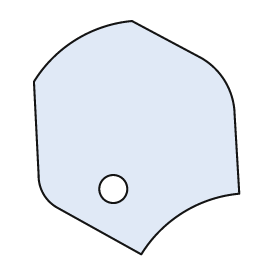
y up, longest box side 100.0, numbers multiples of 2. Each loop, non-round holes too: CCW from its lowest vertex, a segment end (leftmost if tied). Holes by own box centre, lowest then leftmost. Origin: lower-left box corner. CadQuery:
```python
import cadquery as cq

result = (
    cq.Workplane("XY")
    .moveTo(46.0, 0.0)
    .threePointArc((64.0, 18.0), (88.0, 26.0))
    .lineTo(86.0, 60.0)
    .threePointArc((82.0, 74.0), (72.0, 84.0))
    .lineTo(42.0, 100.0)
    .threePointArc((18.0, 92.0), (0.0, 74.0))
    .lineTo(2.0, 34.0)
    .threePointArc((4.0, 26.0), (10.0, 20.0))
    .close()
    .moveTo(34.0, 28.0)
    .circle(6.0)
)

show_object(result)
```